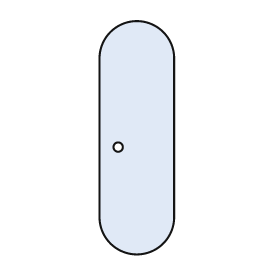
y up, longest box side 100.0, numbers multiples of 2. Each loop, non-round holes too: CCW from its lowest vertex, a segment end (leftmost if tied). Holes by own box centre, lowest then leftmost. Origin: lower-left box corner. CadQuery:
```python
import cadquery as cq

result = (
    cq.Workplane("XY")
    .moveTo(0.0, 16.0)
    .threePointArc((16.0, 0.0), (32.0, 16.0))
    .lineTo(32.0, 84.0)
    .threePointArc((16.0, 100.0), (0.0, 84.0))
    .close()
    .moveTo(8.0, 46.0)
    .circle(2.0)
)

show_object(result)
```